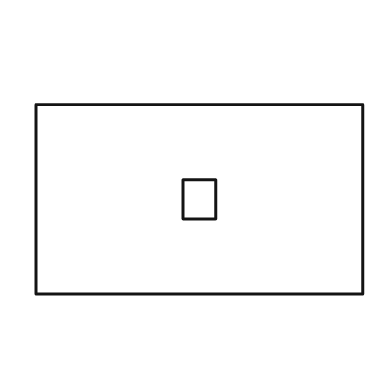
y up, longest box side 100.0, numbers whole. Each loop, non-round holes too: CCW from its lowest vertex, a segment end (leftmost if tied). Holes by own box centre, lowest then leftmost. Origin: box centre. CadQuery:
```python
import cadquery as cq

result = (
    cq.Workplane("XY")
    .moveTo(-50.0, -29.0)
    .lineTo(50.0, -29.0)
    .lineTo(50.0, 29.0)
    .lineTo(-50.0, 29.0)
    .close()
    .moveTo(-5.0, -6.0)
    .lineTo(5.0, -6.0)
    .lineTo(5.0, 6.0)
    .lineTo(-5.0, 6.0)
    .close()
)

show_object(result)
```